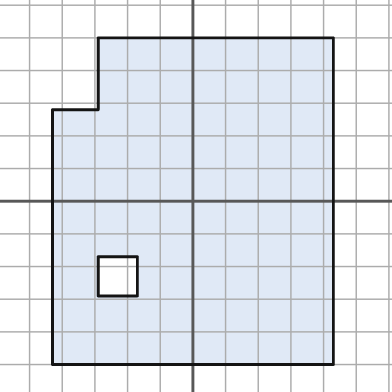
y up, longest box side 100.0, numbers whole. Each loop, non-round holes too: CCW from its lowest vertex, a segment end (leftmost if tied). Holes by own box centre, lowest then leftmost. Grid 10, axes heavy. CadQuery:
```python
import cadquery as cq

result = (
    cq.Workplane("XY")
    .moveTo(-43.0, -50.0)
    .lineTo(43.0, -50.0)
    .lineTo(43.0, 50.0)
    .lineTo(-29.0, 50.0)
    .lineTo(-29.0, 28.0)
    .lineTo(-43.0, 28.0)
    .close()
    .moveTo(-29.0, -29.0)
    .lineTo(-17.0, -29.0)
    .lineTo(-17.0, -17.0)
    .lineTo(-29.0, -17.0)
    .close()
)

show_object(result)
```